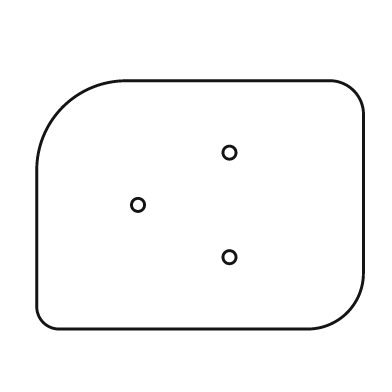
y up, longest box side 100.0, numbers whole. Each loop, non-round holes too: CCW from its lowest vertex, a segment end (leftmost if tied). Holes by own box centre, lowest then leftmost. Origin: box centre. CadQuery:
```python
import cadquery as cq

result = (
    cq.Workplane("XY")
    .moveTo(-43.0, -38.0)
    .lineTo(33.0, -38.0)
    .threePointArc((45.0, -33.0), (50.0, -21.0))
    .lineTo(50.0, 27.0)
    .threePointArc((47.0, 35.0), (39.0, 38.0))
    .lineTo(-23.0, 38.0)
    .threePointArc((-42.0, 30.0), (-50.0, 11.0))
    .lineTo(-50.0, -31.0)
    .threePointArc((-48.0, -36.0), (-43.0, -38.0))
    .close()
    .moveTo(9.0, -16.0)
    .circle(2.0)
    .moveTo(-19.0, 0.0)
    .circle(2.0)
    .moveTo(9.0, 16.0)
    .circle(2.0)
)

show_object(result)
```